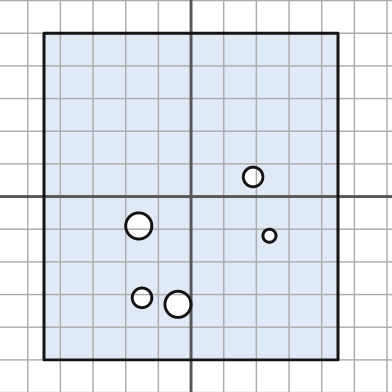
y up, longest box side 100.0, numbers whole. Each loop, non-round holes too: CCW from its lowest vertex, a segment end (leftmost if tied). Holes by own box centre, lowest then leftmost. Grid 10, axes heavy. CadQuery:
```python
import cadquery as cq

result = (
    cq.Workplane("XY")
    .moveTo(-45.0, -50.0)
    .lineTo(45.0, -50.0)
    .lineTo(45.0, 50.0)
    .lineTo(-45.0, 50.0)
    .close()
    .moveTo(-4.0, -33.0)
    .circle(4.0)
    .moveTo(-15.0, -31.0)
    .circle(3.0)
    .moveTo(24.0, -12.0)
    .circle(2.0)
    .moveTo(-16.0, -9.0)
    .circle(4.0)
    .moveTo(19.0, 6.0)
    .circle(3.0)
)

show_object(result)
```